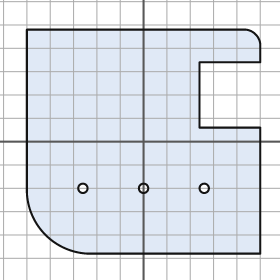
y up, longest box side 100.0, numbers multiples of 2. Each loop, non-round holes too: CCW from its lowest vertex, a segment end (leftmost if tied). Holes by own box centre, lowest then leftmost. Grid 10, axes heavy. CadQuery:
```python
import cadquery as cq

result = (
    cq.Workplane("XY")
    .moveTo(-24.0, -48.0)
    .lineTo(50.0, -48.0)
    .lineTo(50.0, 6.0)
    .lineTo(24.0, 6.0)
    .lineTo(24.0, 34.0)
    .lineTo(50.0, 34.0)
    .lineTo(50.0, 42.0)
    .threePointArc((48.0, 46.0), (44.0, 48.0))
    .lineTo(-50.0, 48.0)
    .lineTo(-50.0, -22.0)
    .threePointArc((-42.0, -40.0), (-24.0, -48.0))
    .close()
    .moveTo(-26.0, -20.0)
    .circle(2.0)
    .moveTo(0.0, -20.0)
    .circle(2.0)
    .moveTo(26.0, -20.0)
    .circle(2.0)
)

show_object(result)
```